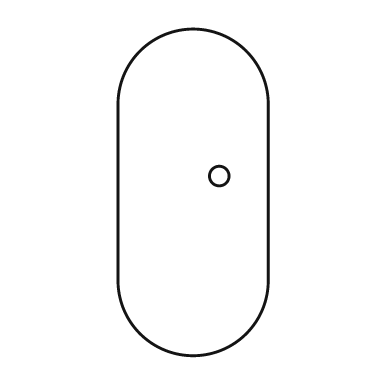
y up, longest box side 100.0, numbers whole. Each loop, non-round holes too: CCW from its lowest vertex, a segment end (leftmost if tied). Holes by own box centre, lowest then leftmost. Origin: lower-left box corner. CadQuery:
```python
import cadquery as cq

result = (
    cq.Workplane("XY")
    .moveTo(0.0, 23.0)
    .threePointArc((23.0, 0.0), (46.0, 23.0))
    .lineTo(46.0, 77.0)
    .threePointArc((23.0, 100.0), (0.0, 77.0))
    .close()
    .moveTo(31.0, 55.0)
    .circle(3.0)
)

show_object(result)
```